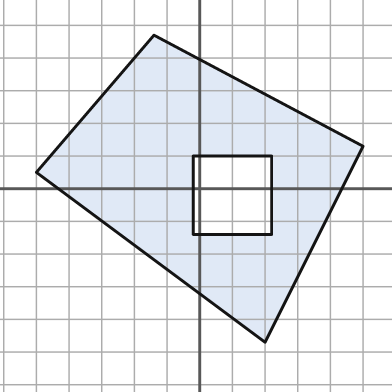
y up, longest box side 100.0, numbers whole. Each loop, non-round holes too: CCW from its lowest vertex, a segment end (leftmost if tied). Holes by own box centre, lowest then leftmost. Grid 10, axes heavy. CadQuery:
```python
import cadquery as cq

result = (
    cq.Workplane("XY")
    .moveTo(20.0, -47.0)
    .lineTo(50.0, 13.0)
    .lineTo(-14.0, 47.0)
    .lineTo(-50.0, 5.0)
    .close()
    .moveTo(-2.0, -14.0)
    .lineTo(22.0, -14.0)
    .lineTo(22.0, 10.0)
    .lineTo(-2.0, 10.0)
    .close()
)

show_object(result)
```